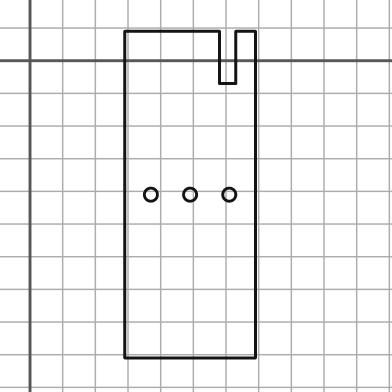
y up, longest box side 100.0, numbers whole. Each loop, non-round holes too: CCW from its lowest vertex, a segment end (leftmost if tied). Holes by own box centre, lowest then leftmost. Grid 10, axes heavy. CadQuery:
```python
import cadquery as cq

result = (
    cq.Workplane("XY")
    .moveTo(29.0, -91.0)
    .lineTo(69.0, -91.0)
    .lineTo(69.0, 9.0)
    .lineTo(63.0, 9.0)
    .lineTo(63.0, -7.0)
    .lineTo(58.0, -7.0)
    .lineTo(58.0, 9.0)
    .lineTo(29.0, 9.0)
    .close()
    .moveTo(37.0, -41.0)
    .circle(2.0)
    .moveTo(49.0, -41.0)
    .circle(2.0)
    .moveTo(61.0, -41.0)
    .circle(2.0)
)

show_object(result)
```